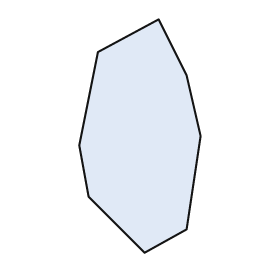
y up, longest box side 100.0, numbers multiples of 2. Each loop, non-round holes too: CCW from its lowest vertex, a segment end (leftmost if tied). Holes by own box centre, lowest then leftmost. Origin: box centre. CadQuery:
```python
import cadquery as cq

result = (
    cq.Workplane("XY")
    .moveTo(2.0, -50.0)
    .lineTo(20.0, -40.0)
    .lineTo(26.0, 0.0)
    .lineTo(20.0, 26.0)
    .lineTo(8.0, 50.0)
    .lineTo(-18.0, 36.0)
    .lineTo(-26.0, -4.0)
    .lineTo(-22.0, -26.0)
    .close()
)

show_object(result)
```